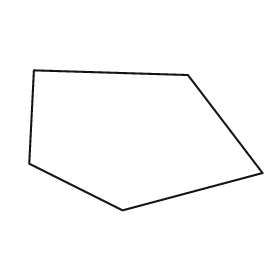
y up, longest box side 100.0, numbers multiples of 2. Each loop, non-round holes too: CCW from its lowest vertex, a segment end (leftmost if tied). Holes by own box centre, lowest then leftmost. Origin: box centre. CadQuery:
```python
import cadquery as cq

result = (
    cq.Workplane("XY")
    .moveTo(-10.0, -30.0)
    .lineTo(50.0, -14.0)
    .lineTo(18.0, 28.0)
    .lineTo(-48.0, 30.0)
    .lineTo(-50.0, -10.0)
    .close()
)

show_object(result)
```